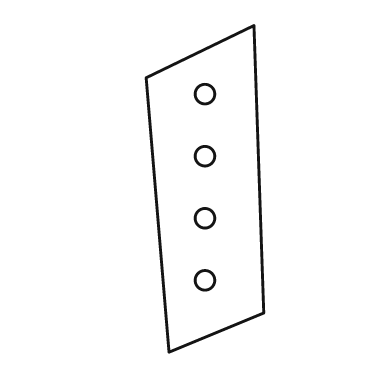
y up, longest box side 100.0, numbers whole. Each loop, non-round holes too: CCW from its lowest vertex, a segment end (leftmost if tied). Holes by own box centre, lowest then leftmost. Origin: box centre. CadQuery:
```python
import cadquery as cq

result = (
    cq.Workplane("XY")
    .moveTo(-11.0, -50.0)
    .lineTo(18.0, -38.0)
    .lineTo(15.0, 50.0)
    .lineTo(-18.0, 34.0)
    .close()
    .moveTo(0.0, -28.0)
    .circle(3.0)
    .moveTo(0.0, -9.0)
    .circle(3.0)
    .moveTo(0.0, 10.0)
    .circle(3.0)
    .moveTo(0.0, 29.0)
    .circle(3.0)
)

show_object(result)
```